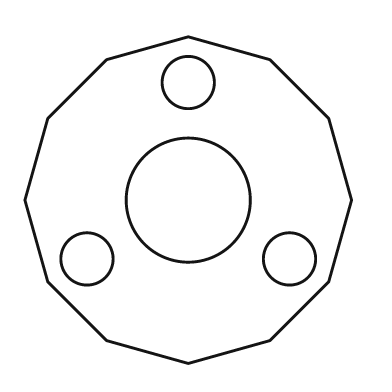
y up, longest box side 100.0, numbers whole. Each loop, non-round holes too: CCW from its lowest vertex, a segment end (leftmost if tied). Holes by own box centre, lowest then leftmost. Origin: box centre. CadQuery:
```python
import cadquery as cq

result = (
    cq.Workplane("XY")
    .moveTo(0.0, -50.0)
    .lineTo(25.0, -43.0)
    .lineTo(43.0, -25.0)
    .lineTo(50.0, 0.0)
    .lineTo(43.0, 25.0)
    .lineTo(25.0, 43.0)
    .lineTo(0.0, 50.0)
    .lineTo(-25.0, 43.0)
    .lineTo(-43.0, 25.0)
    .lineTo(-50.0, 0.0)
    .lineTo(-43.0, -25.0)
    .lineTo(-25.0, -43.0)
    .close()
    .moveTo(-31.0, -18.0)
    .circle(8.0)
    .moveTo(31.0, -18.0)
    .circle(8.0)
    .moveTo(0.0, 0.0)
    .circle(19.0)
    .moveTo(0.0, 36.0)
    .circle(8.0)
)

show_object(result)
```